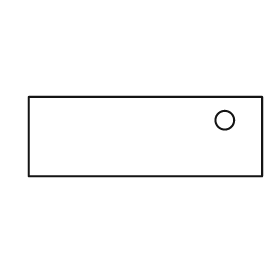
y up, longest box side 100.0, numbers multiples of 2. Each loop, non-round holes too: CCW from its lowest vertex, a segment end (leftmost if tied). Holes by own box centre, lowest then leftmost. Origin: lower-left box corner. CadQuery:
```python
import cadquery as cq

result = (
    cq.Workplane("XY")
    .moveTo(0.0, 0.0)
    .lineTo(100.0, 0.0)
    .lineTo(100.0, 34.0)
    .lineTo(0.0, 34.0)
    .close()
    .moveTo(84.0, 24.0)
    .circle(4.0)
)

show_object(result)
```